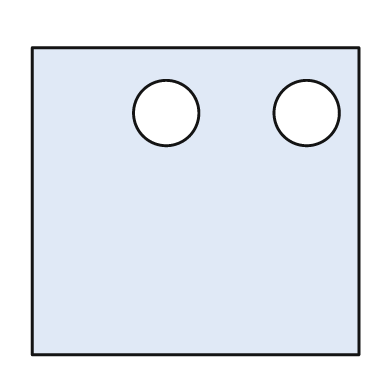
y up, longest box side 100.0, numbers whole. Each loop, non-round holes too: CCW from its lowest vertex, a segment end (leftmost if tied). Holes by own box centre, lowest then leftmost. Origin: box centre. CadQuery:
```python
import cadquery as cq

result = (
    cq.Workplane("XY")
    .moveTo(-50.0, -47.0)
    .lineTo(50.0, -47.0)
    .lineTo(50.0, 47.0)
    .lineTo(-50.0, 47.0)
    .close()
    .moveTo(-9.0, 27.0)
    .circle(10.0)
    .moveTo(34.0, 27.0)
    .circle(10.0)
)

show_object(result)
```